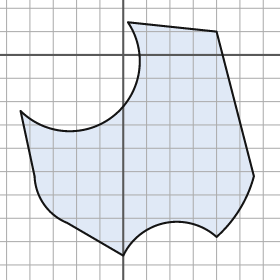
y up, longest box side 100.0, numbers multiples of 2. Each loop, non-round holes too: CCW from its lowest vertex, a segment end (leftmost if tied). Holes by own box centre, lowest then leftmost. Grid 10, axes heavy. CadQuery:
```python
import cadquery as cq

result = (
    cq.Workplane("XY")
    .moveTo(0.0, -86.0)
    .threePointArc((18.0, -72.0), (40.0, -78.0))
    .threePointArc((50.0, -66.0), (56.0, -52.0))
    .lineTo(40.0, 10.0)
    .lineTo(2.0, 14.0)
    .threePointArc((-4.0, -26.0), (-44.0, -24.0))
    .lineTo(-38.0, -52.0)
    .threePointArc((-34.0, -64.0), (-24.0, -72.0))
    .close()
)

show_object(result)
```